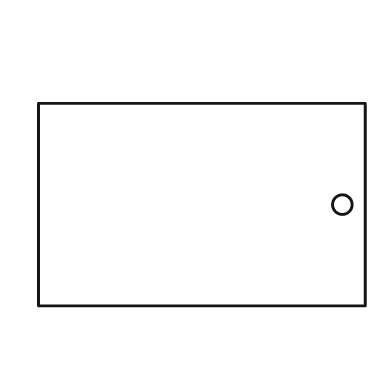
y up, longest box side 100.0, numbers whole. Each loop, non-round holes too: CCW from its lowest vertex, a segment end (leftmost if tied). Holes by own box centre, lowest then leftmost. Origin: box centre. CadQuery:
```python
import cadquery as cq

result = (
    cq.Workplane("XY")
    .moveTo(-50.0, -31.0)
    .lineTo(50.0, -31.0)
    .lineTo(50.0, 31.0)
    .lineTo(-50.0, 31.0)
    .close()
    .moveTo(43.0, 0.0)
    .circle(3.0)
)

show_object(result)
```